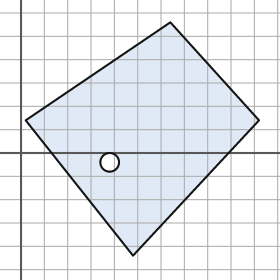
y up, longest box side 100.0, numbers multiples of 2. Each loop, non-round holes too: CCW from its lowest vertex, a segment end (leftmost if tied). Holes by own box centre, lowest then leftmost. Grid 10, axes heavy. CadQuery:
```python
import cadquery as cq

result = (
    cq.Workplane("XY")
    .moveTo(48.0, -44.0)
    .lineTo(102.0, 14.0)
    .lineTo(64.0, 56.0)
    .lineTo(2.0, 14.0)
    .close()
    .moveTo(38.0, -4.0)
    .circle(4.0)
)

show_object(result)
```